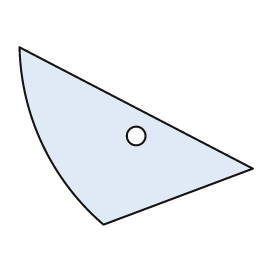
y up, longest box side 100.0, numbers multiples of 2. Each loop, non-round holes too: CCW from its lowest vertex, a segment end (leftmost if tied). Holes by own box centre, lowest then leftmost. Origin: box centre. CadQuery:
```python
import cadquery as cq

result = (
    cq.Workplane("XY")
    .moveTo(-14.0, -38.0)
    .lineTo(50.0, -14.0)
    .lineTo(-50.0, 38.0)
    .threePointArc((-40.0, -4.0), (-14.0, -38.0))
    .close()
    .moveTo(0.0, 0.0)
    .circle(4.0)
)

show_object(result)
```